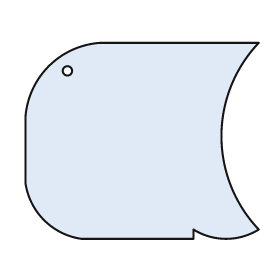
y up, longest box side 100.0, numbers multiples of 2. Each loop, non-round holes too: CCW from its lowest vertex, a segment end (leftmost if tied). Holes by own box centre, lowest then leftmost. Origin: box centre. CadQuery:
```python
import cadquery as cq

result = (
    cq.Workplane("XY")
    .moveTo(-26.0, -42.0)
    .lineTo(22.0, -42.0)
    .lineTo(22.0, -38.0)
    .threePointArc((36.0, -42.0), (50.0, -38.0))
    .threePointArc((34.0, 2.0), (50.0, 42.0))
    .lineTo(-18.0, 42.0)
    .threePointArc((-40.0, 32.0), (-50.0, 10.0))
    .lineTo(-50.0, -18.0)
    .threePointArc((-42.0, -34.0), (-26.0, -42.0))
    .close()
    .moveTo(-32.0, 30.0)
    .circle(2.0)
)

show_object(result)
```